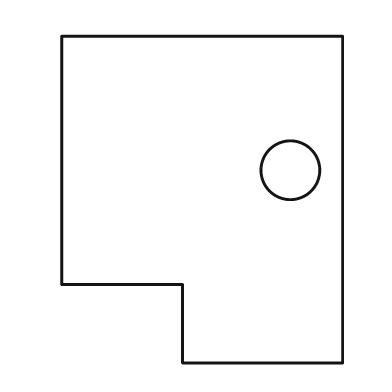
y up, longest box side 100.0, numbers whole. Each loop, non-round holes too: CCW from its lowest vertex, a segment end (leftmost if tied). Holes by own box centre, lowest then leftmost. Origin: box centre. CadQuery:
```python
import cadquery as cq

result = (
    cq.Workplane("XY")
    .moveTo(-6.0, -50.0)
    .lineTo(43.0, -50.0)
    .lineTo(43.0, 50.0)
    .lineTo(-43.0, 50.0)
    .lineTo(-43.0, -26.0)
    .lineTo(-6.0, -26.0)
    .close()
    .moveTo(27.0, 9.0)
    .circle(9.0)
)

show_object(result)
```